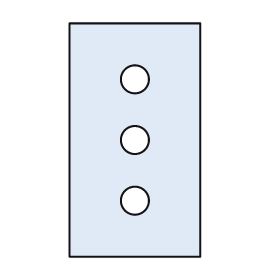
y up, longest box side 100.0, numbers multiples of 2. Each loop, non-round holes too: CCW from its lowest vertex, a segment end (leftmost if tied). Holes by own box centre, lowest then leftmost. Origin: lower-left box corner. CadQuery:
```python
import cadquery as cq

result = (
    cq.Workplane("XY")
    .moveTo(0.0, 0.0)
    .lineTo(56.0, 0.0)
    .lineTo(56.0, 100.0)
    .lineTo(0.0, 100.0)
    .close()
    .moveTo(28.0, 24.0)
    .circle(6.0)
    .moveTo(28.0, 50.0)
    .circle(6.0)
    .moveTo(28.0, 76.0)
    .circle(6.0)
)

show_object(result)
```